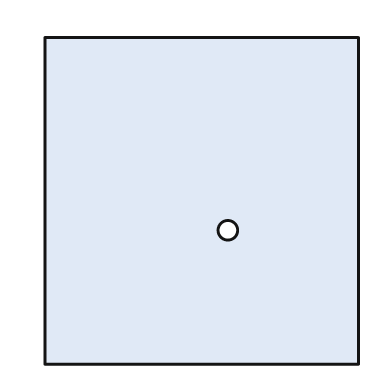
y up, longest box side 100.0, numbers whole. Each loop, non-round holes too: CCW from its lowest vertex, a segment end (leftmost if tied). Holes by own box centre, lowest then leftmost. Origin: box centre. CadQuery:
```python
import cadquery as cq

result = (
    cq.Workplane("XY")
    .moveTo(-48.0, -50.0)
    .lineTo(48.0, -50.0)
    .lineTo(48.0, 50.0)
    .lineTo(-48.0, 50.0)
    .close()
    .moveTo(8.0, -9.0)
    .circle(3.0)
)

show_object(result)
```